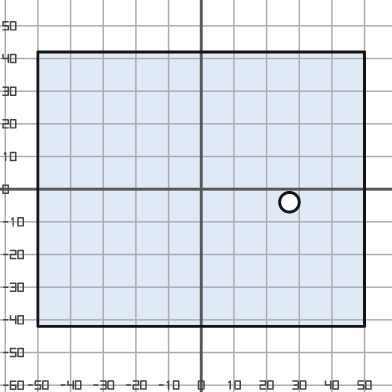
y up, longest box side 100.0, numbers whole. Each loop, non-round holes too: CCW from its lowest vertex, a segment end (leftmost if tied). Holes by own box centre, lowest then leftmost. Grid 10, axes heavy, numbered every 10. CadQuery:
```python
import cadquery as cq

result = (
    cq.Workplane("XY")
    .moveTo(-50.0, -42.0)
    .lineTo(50.0, -42.0)
    .lineTo(50.0, 42.0)
    .lineTo(-50.0, 42.0)
    .close()
    .moveTo(27.0, -4.0)
    .circle(3.0)
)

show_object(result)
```